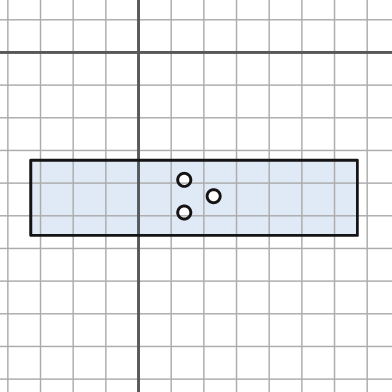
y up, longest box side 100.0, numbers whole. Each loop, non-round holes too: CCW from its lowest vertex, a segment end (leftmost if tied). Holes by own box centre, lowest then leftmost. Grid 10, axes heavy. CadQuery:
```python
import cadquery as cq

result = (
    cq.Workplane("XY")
    .moveTo(-33.0, -56.0)
    .lineTo(67.0, -56.0)
    .lineTo(67.0, -33.0)
    .lineTo(-33.0, -33.0)
    .close()
    .moveTo(14.0, -49.0)
    .circle(2.0)
    .moveTo(23.0, -44.0)
    .circle(2.0)
    .moveTo(14.0, -39.0)
    .circle(2.0)
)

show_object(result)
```